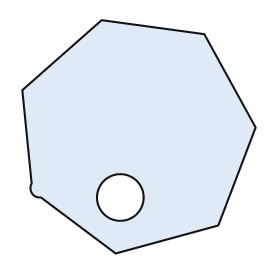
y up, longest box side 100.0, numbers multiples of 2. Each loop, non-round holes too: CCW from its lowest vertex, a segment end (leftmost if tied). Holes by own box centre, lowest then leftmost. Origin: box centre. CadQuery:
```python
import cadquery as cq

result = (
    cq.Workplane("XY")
    .moveTo(-10.0, -50.0)
    .lineTo(34.0, -38.0)
    .lineTo(50.0, 4.0)
    .lineTo(28.0, 44.0)
    .lineTo(-16.0, 50.0)
    .lineTo(-50.0, 20.0)
    .lineTo(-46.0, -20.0)
    .threePointArc((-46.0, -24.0), (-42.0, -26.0))
    .close()
    .moveTo(-8.0, -26.0)
    .circle(10.0)
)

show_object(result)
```